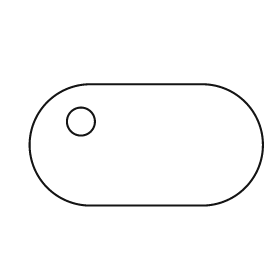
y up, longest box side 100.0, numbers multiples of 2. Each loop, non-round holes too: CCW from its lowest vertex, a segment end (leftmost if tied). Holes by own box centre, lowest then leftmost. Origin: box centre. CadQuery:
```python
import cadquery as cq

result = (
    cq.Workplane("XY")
    .moveTo(-24.0, -26.0)
    .lineTo(24.0, -26.0)
    .threePointArc((50.0, 0.0), (24.0, 26.0))
    .lineTo(-24.0, 26.0)
    .threePointArc((-50.0, 0.0), (-24.0, -26.0))
    .close()
    .moveTo(-28.0, 10.0)
    .circle(6.0)
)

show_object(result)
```